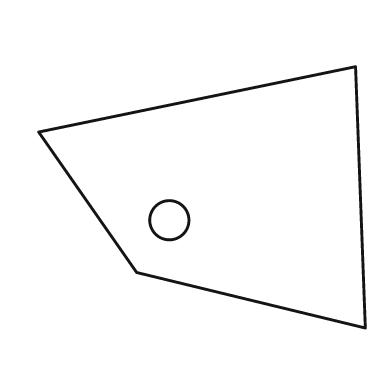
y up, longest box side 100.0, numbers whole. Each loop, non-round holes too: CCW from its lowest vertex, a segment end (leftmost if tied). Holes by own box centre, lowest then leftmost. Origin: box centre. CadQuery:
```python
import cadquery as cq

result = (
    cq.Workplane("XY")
    .moveTo(50.0, -40.0)
    .lineTo(47.0, 40.0)
    .lineTo(-50.0, 20.0)
    .lineTo(-20.0, -23.0)
    .close()
    .moveTo(-10.0, -7.0)
    .circle(6.0)
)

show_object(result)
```